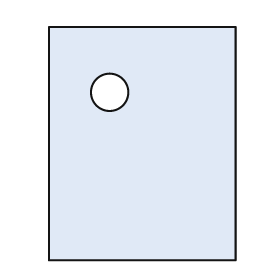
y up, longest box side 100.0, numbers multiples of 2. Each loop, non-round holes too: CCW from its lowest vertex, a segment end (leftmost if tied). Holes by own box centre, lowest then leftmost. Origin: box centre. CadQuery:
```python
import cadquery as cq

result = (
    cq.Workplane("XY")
    .moveTo(-40.0, -50.0)
    .lineTo(40.0, -50.0)
    .lineTo(40.0, 50.0)
    .lineTo(-40.0, 50.0)
    .close()
    .moveTo(-14.0, 22.0)
    .circle(8.0)
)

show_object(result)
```